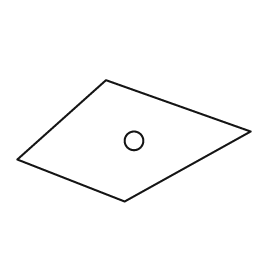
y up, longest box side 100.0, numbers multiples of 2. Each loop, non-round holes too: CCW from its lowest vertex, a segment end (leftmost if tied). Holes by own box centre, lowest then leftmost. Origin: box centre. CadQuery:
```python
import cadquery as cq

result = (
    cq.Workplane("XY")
    .moveTo(-4.0, -26.0)
    .lineTo(50.0, 4.0)
    .lineTo(-12.0, 26.0)
    .lineTo(-50.0, -8.0)
    .close()
    .moveTo(0.0, 0.0)
    .circle(4.0)
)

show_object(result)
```